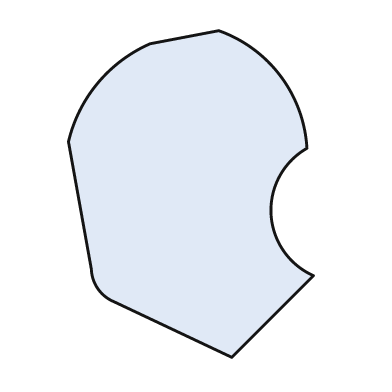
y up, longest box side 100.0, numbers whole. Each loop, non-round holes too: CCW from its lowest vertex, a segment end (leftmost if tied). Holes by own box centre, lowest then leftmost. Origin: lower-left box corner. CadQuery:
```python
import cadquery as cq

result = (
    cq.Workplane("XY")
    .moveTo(50.0, 0.0)
    .lineTo(75.0, 25.0)
    .threePointArc((62.0, 44.0), (73.0, 64.0))
    .threePointArc((65.0, 86.0), (46.0, 100.0))
    .lineTo(25.0, 96.0)
    .threePointArc((9.0, 84.0), (0.0, 66.0))
    .lineTo(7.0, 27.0)
    .threePointArc((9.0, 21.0), (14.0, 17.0))
    .close()
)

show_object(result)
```